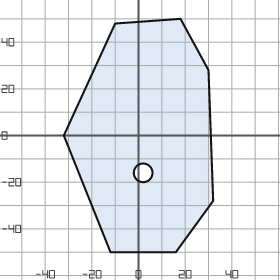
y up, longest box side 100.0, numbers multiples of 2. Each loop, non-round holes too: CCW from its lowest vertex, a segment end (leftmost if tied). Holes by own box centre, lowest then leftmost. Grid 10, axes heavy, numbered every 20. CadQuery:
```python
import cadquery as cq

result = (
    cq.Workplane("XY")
    .moveTo(-12.0, -50.0)
    .lineTo(16.0, -50.0)
    .lineTo(32.0, -28.0)
    .lineTo(30.0, 28.0)
    .lineTo(18.0, 50.0)
    .lineTo(-10.0, 48.0)
    .lineTo(-32.0, 0.0)
    .close()
    .moveTo(2.0, -16.0)
    .circle(4.0)
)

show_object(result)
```